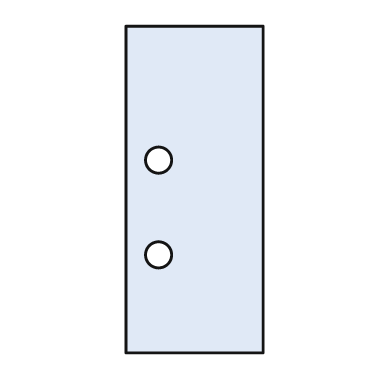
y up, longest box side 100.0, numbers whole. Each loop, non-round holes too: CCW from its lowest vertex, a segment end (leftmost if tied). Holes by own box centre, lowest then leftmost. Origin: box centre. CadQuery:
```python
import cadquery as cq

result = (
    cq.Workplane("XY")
    .moveTo(-21.0, -50.0)
    .lineTo(21.0, -50.0)
    .lineTo(21.0, 50.0)
    .lineTo(-21.0, 50.0)
    .close()
    .moveTo(-11.0, -20.0)
    .circle(4.0)
    .moveTo(-11.0, 9.0)
    .circle(4.0)
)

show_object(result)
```